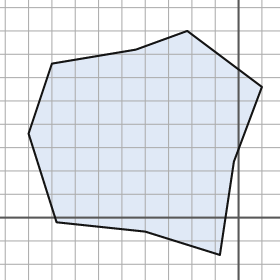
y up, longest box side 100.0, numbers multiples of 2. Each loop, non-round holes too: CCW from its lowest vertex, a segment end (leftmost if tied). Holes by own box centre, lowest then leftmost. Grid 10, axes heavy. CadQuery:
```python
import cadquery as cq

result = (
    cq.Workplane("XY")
    .moveTo(-8.0, -16.0)
    .lineTo(-2.0, 24.0)
    .lineTo(10.0, 56.0)
    .lineTo(-22.0, 80.0)
    .lineTo(-44.0, 72.0)
    .lineTo(-80.0, 66.0)
    .lineTo(-90.0, 36.0)
    .lineTo(-78.0, -2.0)
    .lineTo(-40.0, -6.0)
    .close()
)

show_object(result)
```